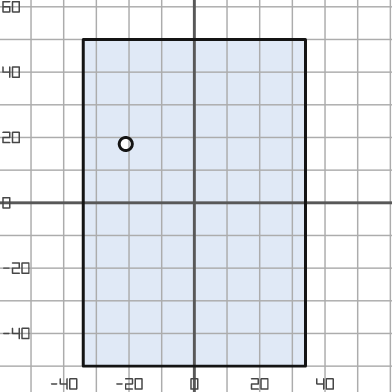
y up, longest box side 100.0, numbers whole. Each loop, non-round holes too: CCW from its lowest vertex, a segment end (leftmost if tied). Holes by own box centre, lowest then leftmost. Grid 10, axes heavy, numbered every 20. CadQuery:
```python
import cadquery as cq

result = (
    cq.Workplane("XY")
    .moveTo(-34.0, -50.0)
    .lineTo(34.0, -50.0)
    .lineTo(34.0, 50.0)
    .lineTo(-34.0, 50.0)
    .close()
    .moveTo(-21.0, 18.0)
    .circle(2.0)
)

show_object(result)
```